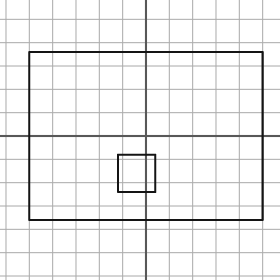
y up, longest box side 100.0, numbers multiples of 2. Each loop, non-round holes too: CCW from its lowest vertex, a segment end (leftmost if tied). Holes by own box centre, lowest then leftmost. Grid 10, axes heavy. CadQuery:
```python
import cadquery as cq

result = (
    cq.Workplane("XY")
    .moveTo(-50.0, -36.0)
    .lineTo(50.0, -36.0)
    .lineTo(50.0, 36.0)
    .lineTo(-50.0, 36.0)
    .close()
    .moveTo(-12.0, -24.0)
    .lineTo(4.0, -24.0)
    .lineTo(4.0, -8.0)
    .lineTo(-12.0, -8.0)
    .close()
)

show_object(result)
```